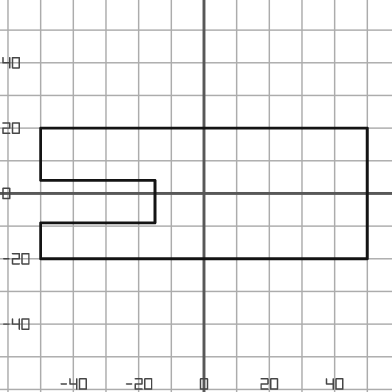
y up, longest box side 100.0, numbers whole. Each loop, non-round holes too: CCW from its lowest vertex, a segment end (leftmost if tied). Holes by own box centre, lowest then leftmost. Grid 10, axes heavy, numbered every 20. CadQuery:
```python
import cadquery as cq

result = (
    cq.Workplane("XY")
    .moveTo(-50.0, -20.0)
    .lineTo(50.0, -20.0)
    .lineTo(50.0, 20.0)
    .lineTo(-50.0, 20.0)
    .lineTo(-50.0, 4.0)
    .lineTo(-15.0, 4.0)
    .lineTo(-15.0, -9.0)
    .lineTo(-50.0, -9.0)
    .close()
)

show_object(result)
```